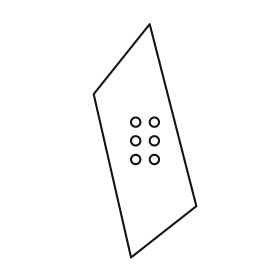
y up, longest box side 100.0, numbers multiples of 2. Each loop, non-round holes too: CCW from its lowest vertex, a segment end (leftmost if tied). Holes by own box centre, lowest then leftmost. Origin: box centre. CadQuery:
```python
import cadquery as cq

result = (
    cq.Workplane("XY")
    .moveTo(-6.0, -50.0)
    .lineTo(22.0, -28.0)
    .lineTo(2.0, 50.0)
    .lineTo(-22.0, 20.0)
    .close()
    .moveTo(-4.0, -8.0)
    .circle(2.0)
    .moveTo(4.0, -8.0)
    .circle(2.0)
    .moveTo(-4.0, 0.0)
    .circle(2.0)
    .moveTo(4.0, 0.0)
    .circle(2.0)
    .moveTo(-4.0, 8.0)
    .circle(2.0)
    .moveTo(4.0, 8.0)
    .circle(2.0)
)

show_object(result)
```